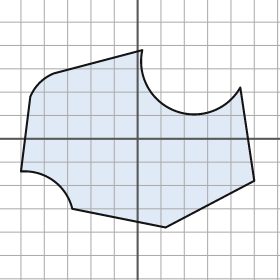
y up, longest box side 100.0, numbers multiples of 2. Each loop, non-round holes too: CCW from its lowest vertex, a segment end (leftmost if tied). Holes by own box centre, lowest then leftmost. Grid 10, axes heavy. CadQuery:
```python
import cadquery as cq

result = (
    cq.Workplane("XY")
    .moveTo(12.0, -38.0)
    .lineTo(50.0, -18.0)
    .lineTo(44.0, 22.0)
    .threePointArc((16.0, 12.0), (2.0, 38.0))
    .lineTo(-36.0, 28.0)
    .threePointArc((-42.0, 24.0), (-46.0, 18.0))
    .lineTo(-50.0, -14.0)
    .threePointArc((-36.0, -18.0), (-28.0, -30.0))
    .close()
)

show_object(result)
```